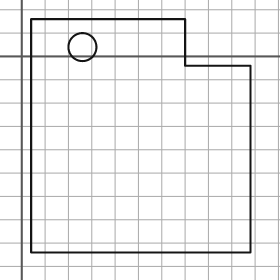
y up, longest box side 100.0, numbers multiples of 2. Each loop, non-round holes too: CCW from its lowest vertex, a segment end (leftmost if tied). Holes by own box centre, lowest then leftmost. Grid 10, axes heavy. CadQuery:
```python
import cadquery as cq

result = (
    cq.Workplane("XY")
    .moveTo(4.0, -84.0)
    .lineTo(98.0, -84.0)
    .lineTo(98.0, -4.0)
    .lineTo(70.0, -4.0)
    .lineTo(70.0, 16.0)
    .lineTo(4.0, 16.0)
    .close()
    .moveTo(26.0, 4.0)
    .circle(6.0)
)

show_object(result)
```